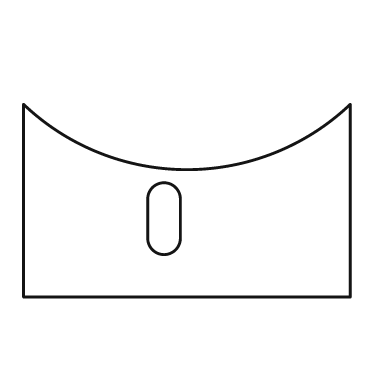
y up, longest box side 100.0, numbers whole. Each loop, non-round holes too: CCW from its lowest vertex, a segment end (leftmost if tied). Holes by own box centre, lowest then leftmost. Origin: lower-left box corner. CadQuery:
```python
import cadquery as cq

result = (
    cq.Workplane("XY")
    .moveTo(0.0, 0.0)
    .lineTo(100.0, 0.0)
    .lineTo(100.0, 59.0)
    .threePointArc((50.0, 39.0), (0.0, 59.0))
    .close()
    .moveTo(38.0, 18.0)
    .threePointArc((43.0, 13.0), (48.0, 18.0))
    .lineTo(48.0, 30.0)
    .threePointArc((43.0, 35.0), (38.0, 30.0))
    .close()
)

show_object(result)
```